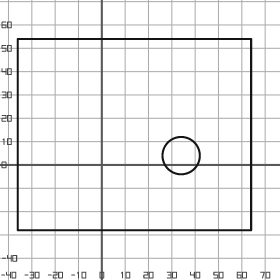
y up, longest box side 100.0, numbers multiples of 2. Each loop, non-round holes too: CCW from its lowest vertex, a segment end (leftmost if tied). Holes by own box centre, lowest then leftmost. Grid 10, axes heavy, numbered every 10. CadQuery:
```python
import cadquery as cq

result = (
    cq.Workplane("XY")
    .moveTo(-36.0, -28.0)
    .lineTo(64.0, -28.0)
    .lineTo(64.0, 54.0)
    .lineTo(-36.0, 54.0)
    .close()
    .moveTo(34.0, 4.0)
    .circle(8.0)
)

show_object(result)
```